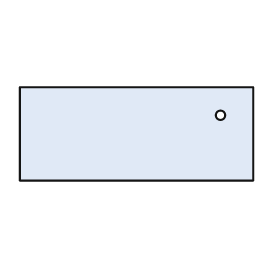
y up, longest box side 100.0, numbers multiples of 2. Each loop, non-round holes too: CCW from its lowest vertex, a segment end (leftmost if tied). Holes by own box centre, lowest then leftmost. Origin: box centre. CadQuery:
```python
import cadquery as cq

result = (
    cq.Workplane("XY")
    .moveTo(-50.0, -20.0)
    .lineTo(50.0, -20.0)
    .lineTo(50.0, 20.0)
    .lineTo(-50.0, 20.0)
    .close()
    .moveTo(36.0, 8.0)
    .circle(2.0)
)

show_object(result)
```